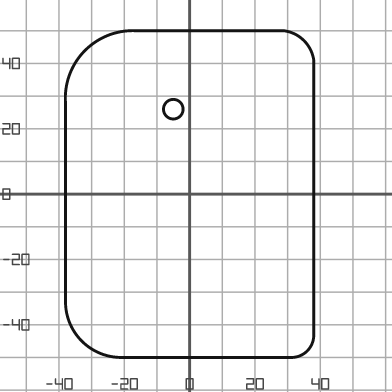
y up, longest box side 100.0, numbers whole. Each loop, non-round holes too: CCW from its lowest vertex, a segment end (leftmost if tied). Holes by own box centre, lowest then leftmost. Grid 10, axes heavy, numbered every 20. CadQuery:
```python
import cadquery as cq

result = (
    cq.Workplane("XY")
    .moveTo(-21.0, -50.0)
    .lineTo(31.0, -50.0)
    .threePointArc((36.0, -48.0), (38.0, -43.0))
    .lineTo(38.0, 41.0)
    .threePointArc((35.0, 47.0), (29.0, 50.0))
    .lineTo(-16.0, 50.0)
    .threePointArc((-32.0, 44.0), (-38.0, 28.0))
    .lineTo(-38.0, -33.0)
    .threePointArc((-33.0, -45.0), (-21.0, -50.0))
    .close()
    .moveTo(-5.0, 26.0)
    .circle(3.0)
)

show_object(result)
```